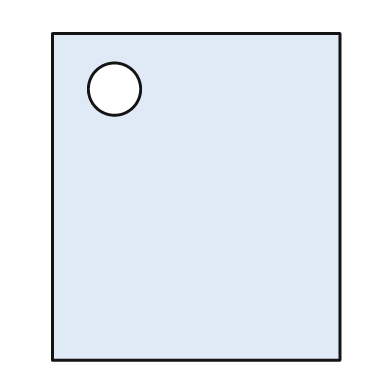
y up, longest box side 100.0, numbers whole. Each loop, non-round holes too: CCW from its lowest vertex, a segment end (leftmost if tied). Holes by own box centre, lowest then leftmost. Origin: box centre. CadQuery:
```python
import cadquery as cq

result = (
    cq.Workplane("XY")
    .moveTo(-44.0, -50.0)
    .lineTo(44.0, -50.0)
    .lineTo(44.0, 50.0)
    .lineTo(-44.0, 50.0)
    .close()
    .moveTo(-25.0, 33.0)
    .circle(8.0)
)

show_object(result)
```